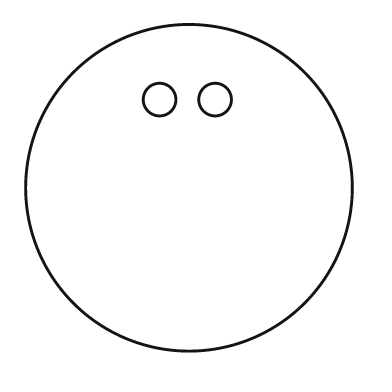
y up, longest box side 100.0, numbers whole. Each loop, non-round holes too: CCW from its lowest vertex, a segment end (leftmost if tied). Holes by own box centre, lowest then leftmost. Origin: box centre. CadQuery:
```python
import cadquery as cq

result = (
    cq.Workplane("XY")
    .moveTo(0.0, 0.0)
    .circle(50.0)
    .moveTo(-9.0, 27.0)
    .circle(5.0)
    .moveTo(8.0, 27.0)
    .circle(5.0)
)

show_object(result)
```